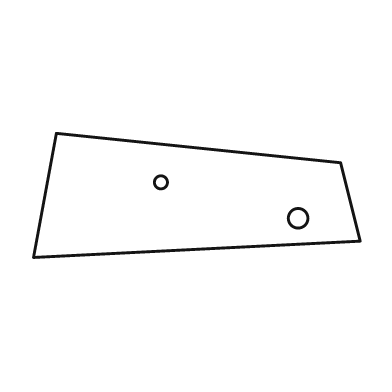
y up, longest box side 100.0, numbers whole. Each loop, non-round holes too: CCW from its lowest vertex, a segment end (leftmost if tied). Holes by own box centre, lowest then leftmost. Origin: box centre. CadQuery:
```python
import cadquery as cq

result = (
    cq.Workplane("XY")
    .moveTo(-50.0, -19.0)
    .lineTo(50.0, -14.0)
    .lineTo(44.0, 10.0)
    .lineTo(-43.0, 19.0)
    .close()
    .moveTo(31.0, -7.0)
    .circle(3.0)
    .moveTo(-11.0, 4.0)
    .circle(2.0)
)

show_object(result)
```